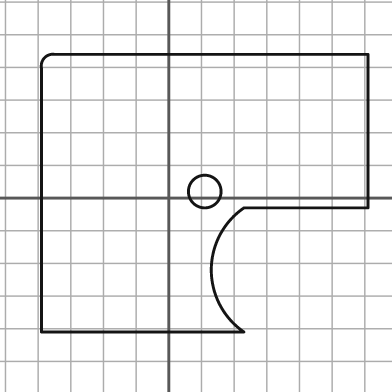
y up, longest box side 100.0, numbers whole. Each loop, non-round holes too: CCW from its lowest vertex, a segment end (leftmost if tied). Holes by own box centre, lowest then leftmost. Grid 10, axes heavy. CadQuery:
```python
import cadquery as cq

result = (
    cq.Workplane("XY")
    .moveTo(-39.0, -41.0)
    .lineTo(23.0, -41.0)
    .threePointArc((13.0, -22.0), (23.0, -3.0))
    .lineTo(61.0, -3.0)
    .lineTo(61.0, 44.0)
    .lineTo(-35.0, 44.0)
    .threePointArc((-38.0, 43.0), (-39.0, 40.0))
    .close()
    .moveTo(11.0, 2.0)
    .circle(5.0)
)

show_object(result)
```